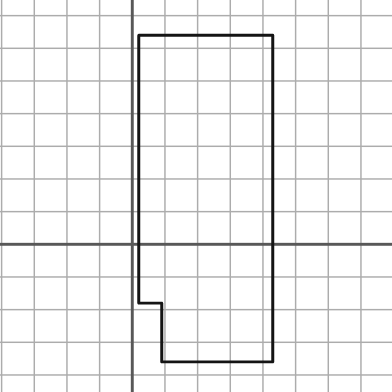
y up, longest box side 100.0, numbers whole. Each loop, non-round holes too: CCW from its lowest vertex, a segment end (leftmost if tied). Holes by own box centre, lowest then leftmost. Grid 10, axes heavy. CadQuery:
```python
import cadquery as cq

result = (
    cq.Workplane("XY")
    .moveTo(9.0, -36.0)
    .lineTo(43.0, -36.0)
    .lineTo(43.0, 64.0)
    .lineTo(2.0, 64.0)
    .lineTo(2.0, -18.0)
    .lineTo(9.0, -18.0)
    .close()
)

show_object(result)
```